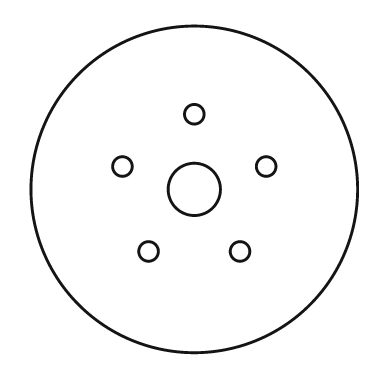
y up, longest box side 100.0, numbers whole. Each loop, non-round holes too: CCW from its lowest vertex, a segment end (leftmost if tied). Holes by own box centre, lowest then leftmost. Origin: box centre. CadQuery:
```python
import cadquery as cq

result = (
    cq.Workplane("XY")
    .moveTo(0.0, 0.0)
    .circle(50.0)
    .moveTo(-14.0, -19.0)
    .circle(3.0)
    .moveTo(14.0, -19.0)
    .circle(3.0)
    .moveTo(0.0, 0.0)
    .circle(8.0)
    .moveTo(-22.0, 7.0)
    .circle(3.0)
    .moveTo(22.0, 7.0)
    .circle(3.0)
    .moveTo(0.0, 23.0)
    .circle(3.0)
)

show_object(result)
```